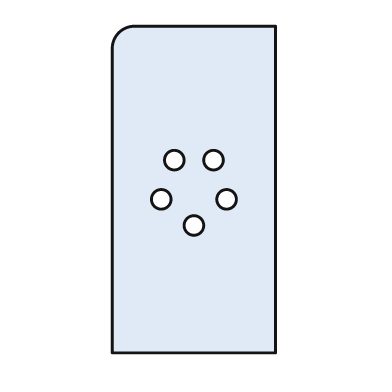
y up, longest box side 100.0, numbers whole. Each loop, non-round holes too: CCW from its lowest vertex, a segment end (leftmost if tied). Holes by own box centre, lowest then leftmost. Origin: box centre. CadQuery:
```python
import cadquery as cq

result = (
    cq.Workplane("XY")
    .moveTo(-25.0, -50.0)
    .lineTo(25.0, -50.0)
    .lineTo(25.0, 50.0)
    .lineTo(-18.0, 50.0)
    .threePointArc((-23.0, 48.0), (-25.0, 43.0))
    .close()
    .moveTo(0.0, -11.0)
    .circle(3.0)
    .moveTo(-10.0, -3.0)
    .circle(3.0)
    .moveTo(10.0, -3.0)
    .circle(3.0)
    .moveTo(-6.0, 9.0)
    .circle(3.0)
    .moveTo(6.0, 9.0)
    .circle(3.0)
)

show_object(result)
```